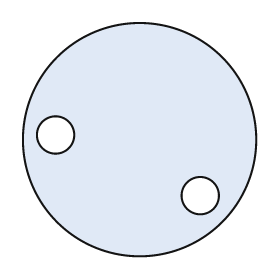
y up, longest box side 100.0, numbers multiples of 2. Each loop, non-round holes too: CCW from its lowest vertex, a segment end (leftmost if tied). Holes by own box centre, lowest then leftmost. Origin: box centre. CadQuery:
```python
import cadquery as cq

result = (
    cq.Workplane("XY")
    .moveTo(0.0, 0.0)
    .circle(50.0)
    .moveTo(26.0, -24.0)
    .circle(8.0)
    .moveTo(-36.0, 2.0)
    .circle(8.0)
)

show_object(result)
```